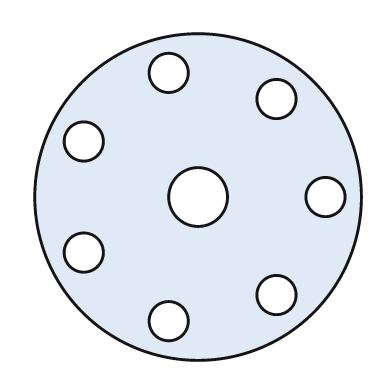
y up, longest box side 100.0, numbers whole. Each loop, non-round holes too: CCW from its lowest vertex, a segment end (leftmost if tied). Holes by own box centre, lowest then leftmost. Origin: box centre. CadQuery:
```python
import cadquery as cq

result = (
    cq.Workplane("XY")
    .moveTo(0.0, 0.0)
    .circle(50.0)
    .moveTo(-9.0, -38.0)
    .circle(6.0)
    .moveTo(24.0, -30.0)
    .circle(6.0)
    .moveTo(-35.0, -17.0)
    .circle(6.0)
    .moveTo(0.0, 0.0)
    .circle(9.0)
    .moveTo(39.0, 0.0)
    .circle(6.0)
    .moveTo(-35.0, 17.0)
    .circle(6.0)
    .moveTo(24.0, 30.0)
    .circle(6.0)
    .moveTo(-9.0, 38.0)
    .circle(6.0)
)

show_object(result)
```